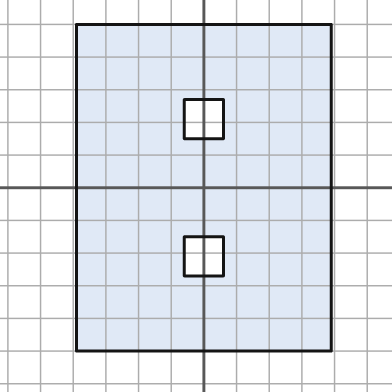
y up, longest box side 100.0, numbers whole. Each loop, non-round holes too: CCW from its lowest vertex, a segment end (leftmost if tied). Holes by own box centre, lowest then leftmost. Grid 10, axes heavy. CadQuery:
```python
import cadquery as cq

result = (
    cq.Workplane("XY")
    .moveTo(-39.0, -50.0)
    .lineTo(39.0, -50.0)
    .lineTo(39.0, 50.0)
    .lineTo(-39.0, 50.0)
    .close()
    .moveTo(-6.0, -27.0)
    .lineTo(6.0, -27.0)
    .lineTo(6.0, -15.0)
    .lineTo(-6.0, -15.0)
    .close()
    .moveTo(-6.0, 15.0)
    .lineTo(6.0, 15.0)
    .lineTo(6.0, 27.0)
    .lineTo(-6.0, 27.0)
    .close()
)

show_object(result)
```